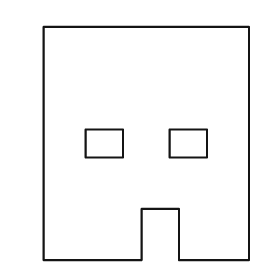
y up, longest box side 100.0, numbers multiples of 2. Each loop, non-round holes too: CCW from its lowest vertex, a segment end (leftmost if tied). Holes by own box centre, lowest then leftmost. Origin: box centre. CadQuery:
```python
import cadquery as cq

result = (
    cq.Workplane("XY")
    .moveTo(-44.0, -50.0)
    .lineTo(-2.0, -50.0)
    .lineTo(-2.0, -28.0)
    .lineTo(14.0, -28.0)
    .lineTo(14.0, -50.0)
    .lineTo(44.0, -50.0)
    .lineTo(44.0, 50.0)
    .lineTo(-44.0, 50.0)
    .close()
    .moveTo(-26.0, -6.0)
    .lineTo(-10.0, -6.0)
    .lineTo(-10.0, 6.0)
    .lineTo(-26.0, 6.0)
    .close()
    .moveTo(10.0, -6.0)
    .lineTo(26.0, -6.0)
    .lineTo(26.0, 6.0)
    .lineTo(10.0, 6.0)
    .close()
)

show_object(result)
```